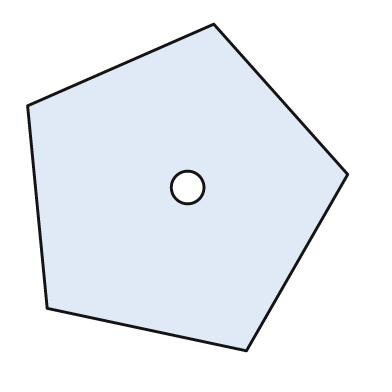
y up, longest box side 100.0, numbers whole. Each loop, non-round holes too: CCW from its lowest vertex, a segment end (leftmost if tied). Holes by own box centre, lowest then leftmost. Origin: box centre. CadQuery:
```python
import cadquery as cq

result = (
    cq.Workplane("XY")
    .moveTo(18.0, -50.0)
    .lineTo(49.0, 4.0)
    .lineTo(8.0, 50.0)
    .lineTo(-49.0, 25.0)
    .lineTo(-43.0, -37.0)
    .close()
    .moveTo(0.0, 0.0)
    .circle(5.0)
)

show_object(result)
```